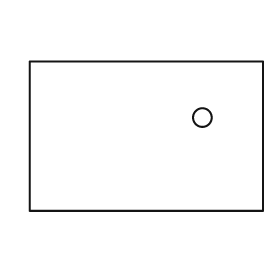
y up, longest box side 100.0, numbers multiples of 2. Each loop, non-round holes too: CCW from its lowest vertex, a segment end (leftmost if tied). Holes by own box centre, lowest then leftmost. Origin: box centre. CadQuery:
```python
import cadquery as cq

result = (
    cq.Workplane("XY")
    .moveTo(-50.0, -32.0)
    .lineTo(50.0, -32.0)
    .lineTo(50.0, 32.0)
    .lineTo(-50.0, 32.0)
    .close()
    .moveTo(24.0, 8.0)
    .circle(4.0)
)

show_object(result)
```